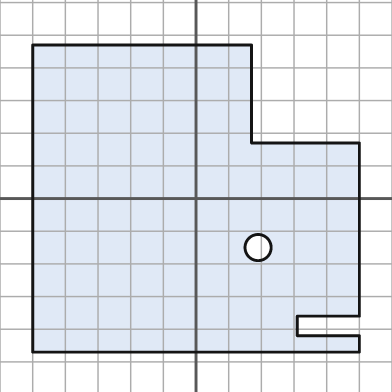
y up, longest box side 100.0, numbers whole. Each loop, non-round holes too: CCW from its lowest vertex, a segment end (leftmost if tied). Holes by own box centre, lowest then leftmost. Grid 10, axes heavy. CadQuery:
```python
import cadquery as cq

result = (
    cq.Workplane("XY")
    .moveTo(-50.0, -47.0)
    .lineTo(50.0, -47.0)
    .lineTo(50.0, -42.0)
    .lineTo(31.0, -42.0)
    .lineTo(31.0, -36.0)
    .lineTo(50.0, -36.0)
    .lineTo(50.0, 17.0)
    .lineTo(17.0, 17.0)
    .lineTo(17.0, 47.0)
    .lineTo(-50.0, 47.0)
    .close()
    .moveTo(19.0, -15.0)
    .circle(4.0)
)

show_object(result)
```